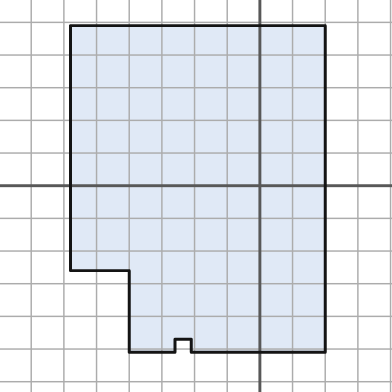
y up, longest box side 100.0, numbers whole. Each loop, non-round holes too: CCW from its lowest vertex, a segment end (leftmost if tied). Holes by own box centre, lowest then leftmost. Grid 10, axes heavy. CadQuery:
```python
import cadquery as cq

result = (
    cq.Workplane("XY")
    .moveTo(-40.0, -51.0)
    .lineTo(-26.0, -51.0)
    .lineTo(-26.0, -47.0)
    .lineTo(-21.0, -47.0)
    .lineTo(-21.0, -51.0)
    .lineTo(20.0, -51.0)
    .lineTo(20.0, 49.0)
    .lineTo(-58.0, 49.0)
    .lineTo(-58.0, -26.0)
    .lineTo(-40.0, -26.0)
    .close()
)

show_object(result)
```